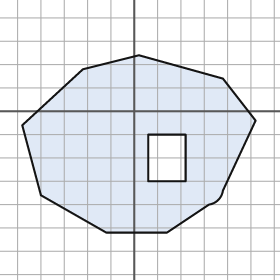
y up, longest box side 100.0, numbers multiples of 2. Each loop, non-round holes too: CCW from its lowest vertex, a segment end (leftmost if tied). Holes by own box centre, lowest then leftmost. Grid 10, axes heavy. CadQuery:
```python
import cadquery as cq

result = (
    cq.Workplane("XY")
    .moveTo(-12.0, -52.0)
    .lineTo(14.0, -52.0)
    .lineTo(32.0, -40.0)
    .threePointArc((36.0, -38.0), (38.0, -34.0))
    .lineTo(52.0, -4.0)
    .lineTo(38.0, 14.0)
    .lineTo(2.0, 24.0)
    .lineTo(-22.0, 18.0)
    .lineTo(-48.0, -6.0)
    .lineTo(-40.0, -36.0)
    .close()
    .moveTo(6.0, -30.0)
    .lineTo(22.0, -30.0)
    .lineTo(22.0, -10.0)
    .lineTo(6.0, -10.0)
    .close()
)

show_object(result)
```